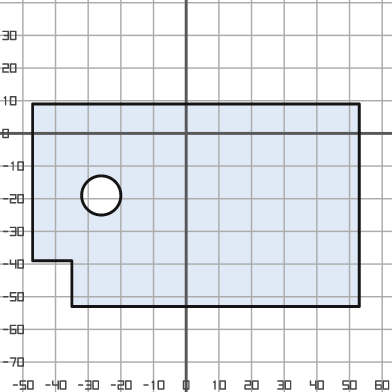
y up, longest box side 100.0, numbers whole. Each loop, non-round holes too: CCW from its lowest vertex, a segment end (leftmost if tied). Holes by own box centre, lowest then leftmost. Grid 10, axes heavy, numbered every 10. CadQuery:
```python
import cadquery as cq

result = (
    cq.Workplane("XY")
    .moveTo(-35.0, -53.0)
    .lineTo(53.0, -53.0)
    .lineTo(53.0, 9.0)
    .lineTo(-47.0, 9.0)
    .lineTo(-47.0, -39.0)
    .lineTo(-35.0, -39.0)
    .close()
    .moveTo(-26.0, -19.0)
    .circle(6.0)
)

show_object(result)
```